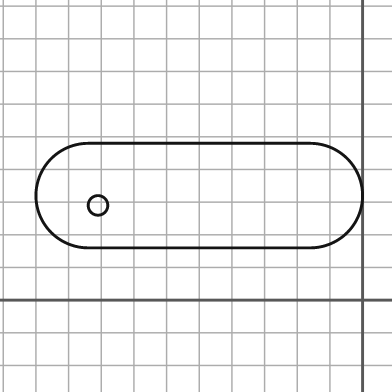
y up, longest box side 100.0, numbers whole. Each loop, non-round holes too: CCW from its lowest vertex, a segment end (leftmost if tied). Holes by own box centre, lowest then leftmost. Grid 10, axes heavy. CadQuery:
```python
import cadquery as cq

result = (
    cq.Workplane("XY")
    .moveTo(-84.0, 16.0)
    .lineTo(-16.0, 16.0)
    .threePointArc((0.0, 32.0), (-16.0, 48.0))
    .lineTo(-84.0, 48.0)
    .threePointArc((-100.0, 32.0), (-84.0, 16.0))
    .close()
    .moveTo(-81.0, 29.0)
    .circle(3.0)
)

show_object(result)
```